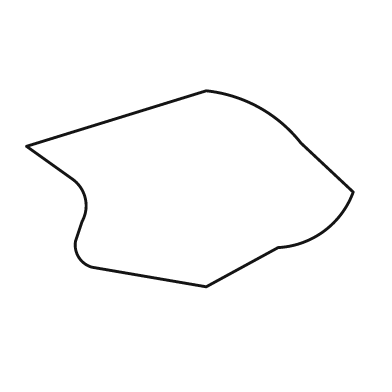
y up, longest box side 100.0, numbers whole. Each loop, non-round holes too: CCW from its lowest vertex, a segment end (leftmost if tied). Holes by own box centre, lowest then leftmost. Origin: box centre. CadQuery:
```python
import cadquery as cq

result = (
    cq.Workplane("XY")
    .moveTo(5.0, -30.0)
    .lineTo(27.0, -18.0)
    .threePointArc((41.0, -13.0), (50.0, -1.0))
    .lineTo(34.0, 14.0)
    .threePointArc((21.0, 25.0), (5.0, 30.0))
    .lineTo(-50.0, 13.0)
    .lineTo(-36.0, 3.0)
    .threePointArc((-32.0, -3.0), (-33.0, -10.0))
    .lineTo(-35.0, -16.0)
    .threePointArc((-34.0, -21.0), (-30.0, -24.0))
    .close()
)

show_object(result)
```